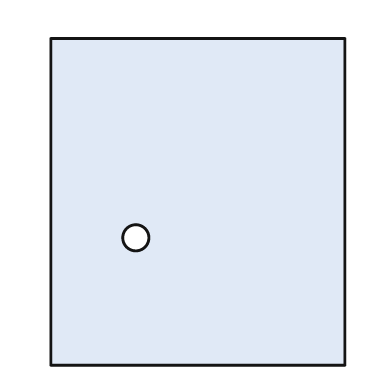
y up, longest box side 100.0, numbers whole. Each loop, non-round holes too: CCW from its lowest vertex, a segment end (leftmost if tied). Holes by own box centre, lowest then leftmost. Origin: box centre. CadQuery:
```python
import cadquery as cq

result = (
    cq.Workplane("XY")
    .moveTo(-45.0, -50.0)
    .lineTo(45.0, -50.0)
    .lineTo(45.0, 50.0)
    .lineTo(-45.0, 50.0)
    .close()
    .moveTo(-19.0, -11.0)
    .circle(4.0)
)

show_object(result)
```